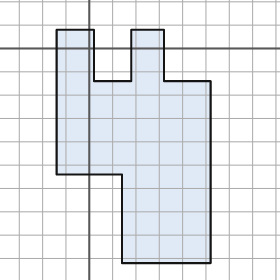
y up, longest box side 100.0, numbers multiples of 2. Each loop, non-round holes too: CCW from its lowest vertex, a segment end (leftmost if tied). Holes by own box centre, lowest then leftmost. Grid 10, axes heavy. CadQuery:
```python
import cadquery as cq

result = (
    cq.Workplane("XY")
    .moveTo(14.0, -92.0)
    .lineTo(52.0, -92.0)
    .lineTo(52.0, -14.0)
    .lineTo(32.0, -14.0)
    .lineTo(32.0, 8.0)
    .lineTo(18.0, 8.0)
    .lineTo(18.0, -14.0)
    .lineTo(2.0, -14.0)
    .lineTo(2.0, 8.0)
    .lineTo(-14.0, 8.0)
    .lineTo(-14.0, -54.0)
    .lineTo(14.0, -54.0)
    .close()
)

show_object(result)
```